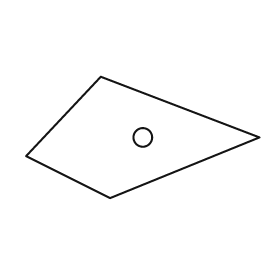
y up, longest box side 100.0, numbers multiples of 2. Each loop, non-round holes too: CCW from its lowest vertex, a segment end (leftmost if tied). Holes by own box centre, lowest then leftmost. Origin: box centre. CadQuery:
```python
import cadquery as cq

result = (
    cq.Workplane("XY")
    .moveTo(-14.0, -26.0)
    .lineTo(50.0, 0.0)
    .lineTo(-18.0, 26.0)
    .lineTo(-50.0, -8.0)
    .close()
    .moveTo(0.0, 0.0)
    .circle(4.0)
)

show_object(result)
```